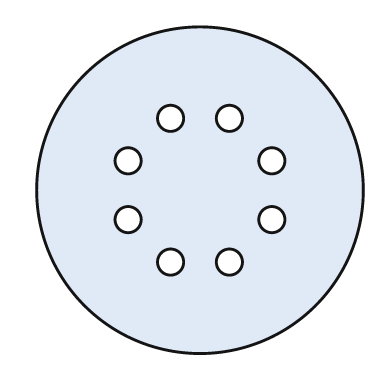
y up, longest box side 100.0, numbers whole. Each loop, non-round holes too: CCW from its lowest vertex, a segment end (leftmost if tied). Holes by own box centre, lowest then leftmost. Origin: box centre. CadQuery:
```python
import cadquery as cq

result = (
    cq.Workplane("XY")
    .moveTo(0.0, 0.0)
    .circle(50.0)
    .moveTo(-9.0, -22.0)
    .circle(4.0)
    .moveTo(9.0, -22.0)
    .circle(4.0)
    .moveTo(-22.0, -9.0)
    .circle(4.0)
    .moveTo(22.0, -9.0)
    .circle(4.0)
    .moveTo(-22.0, 9.0)
    .circle(4.0)
    .moveTo(22.0, 9.0)
    .circle(4.0)
    .moveTo(-9.0, 22.0)
    .circle(4.0)
    .moveTo(9.0, 22.0)
    .circle(4.0)
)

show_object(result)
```